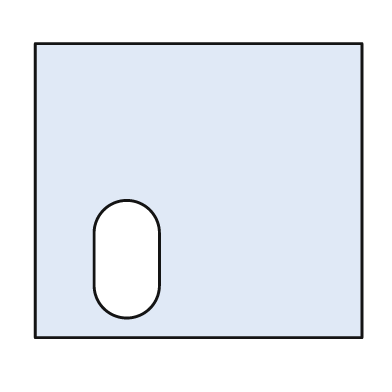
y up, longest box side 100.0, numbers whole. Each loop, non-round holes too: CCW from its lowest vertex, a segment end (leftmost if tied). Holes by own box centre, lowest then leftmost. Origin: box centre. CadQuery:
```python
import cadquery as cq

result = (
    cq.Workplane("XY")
    .moveTo(-50.0, -45.0)
    .lineTo(50.0, -45.0)
    .lineTo(50.0, 45.0)
    .lineTo(-50.0, 45.0)
    .close()
    .moveTo(-32.0, -29.0)
    .threePointArc((-22.0, -39.0), (-12.0, -29.0))
    .lineTo(-12.0, -13.0)
    .threePointArc((-22.0, -3.0), (-32.0, -13.0))
    .close()
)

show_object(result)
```